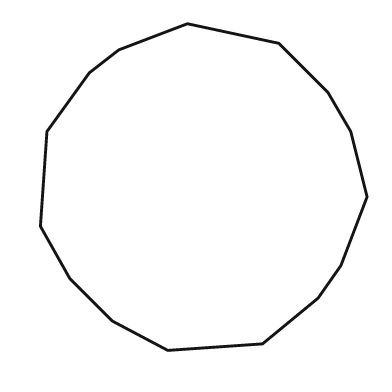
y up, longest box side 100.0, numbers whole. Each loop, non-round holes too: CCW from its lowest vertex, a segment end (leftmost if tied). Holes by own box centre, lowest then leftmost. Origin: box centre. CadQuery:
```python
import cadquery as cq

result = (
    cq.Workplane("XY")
    .moveTo(-11.0, -50.0)
    .lineTo(18.0, -48.0)
    .lineTo(35.0, -34.0)
    .lineTo(42.0, -24.0)
    .lineTo(50.0, -3.0)
    .lineTo(45.0, 17.0)
    .lineTo(38.0, 29.0)
    .lineTo(23.0, 44.0)
    .lineTo(-5.0, 50.0)
    .lineTo(-26.0, 42.0)
    .lineTo(-35.0, 35.0)
    .lineTo(-48.0, 17.0)
    .lineTo(-50.0, -12.0)
    .lineTo(-41.0, -28.0)
    .lineTo(-28.0, -41.0)
    .close()
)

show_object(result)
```